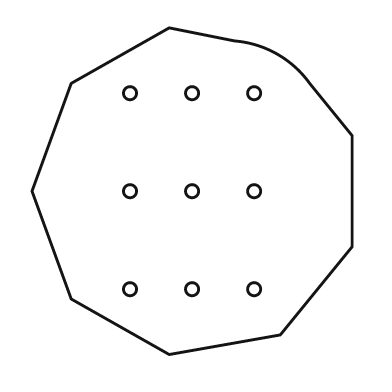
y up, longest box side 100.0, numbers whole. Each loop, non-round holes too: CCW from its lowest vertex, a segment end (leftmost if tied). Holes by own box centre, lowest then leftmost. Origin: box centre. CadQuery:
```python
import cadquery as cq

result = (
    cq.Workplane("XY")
    .moveTo(-7.0, -50.0)
    .lineTo(27.0, -44.0)
    .lineTo(49.0, -17.0)
    .lineTo(49.0, 17.0)
    .lineTo(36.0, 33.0)
    .threePointArc((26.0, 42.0), (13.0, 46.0))
    .lineTo(-7.0, 50.0)
    .lineTo(-37.0, 33.0)
    .lineTo(-49.0, 0.0)
    .lineTo(-37.0, -33.0)
    .close()
    .moveTo(-19.0, -30.0)
    .circle(2.0)
    .moveTo(0.0, -30.0)
    .circle(2.0)
    .moveTo(19.0, -30.0)
    .circle(2.0)
    .moveTo(-19.0, 0.0)
    .circle(2.0)
    .moveTo(0.0, 0.0)
    .circle(2.0)
    .moveTo(19.0, 0.0)
    .circle(2.0)
    .moveTo(-19.0, 30.0)
    .circle(2.0)
    .moveTo(0.0, 30.0)
    .circle(2.0)
    .moveTo(19.0, 30.0)
    .circle(2.0)
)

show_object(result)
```